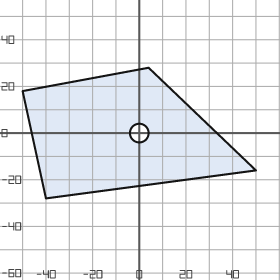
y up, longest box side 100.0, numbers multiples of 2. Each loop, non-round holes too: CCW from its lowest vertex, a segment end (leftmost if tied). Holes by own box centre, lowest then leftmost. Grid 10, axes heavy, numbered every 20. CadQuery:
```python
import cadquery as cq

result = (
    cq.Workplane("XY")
    .moveTo(-40.0, -28.0)
    .lineTo(50.0, -16.0)
    .lineTo(4.0, 28.0)
    .lineTo(-50.0, 18.0)
    .close()
    .moveTo(0.0, 0.0)
    .circle(4.0)
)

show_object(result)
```